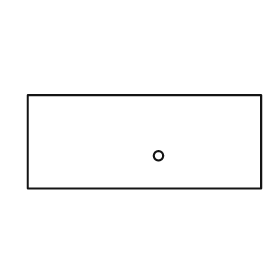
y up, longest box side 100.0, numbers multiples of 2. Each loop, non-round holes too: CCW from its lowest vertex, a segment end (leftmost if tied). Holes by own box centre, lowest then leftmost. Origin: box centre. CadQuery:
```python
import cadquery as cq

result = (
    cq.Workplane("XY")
    .moveTo(-50.0, -20.0)
    .lineTo(50.0, -20.0)
    .lineTo(50.0, 20.0)
    .lineTo(-50.0, 20.0)
    .close()
    .moveTo(6.0, -6.0)
    .circle(2.0)
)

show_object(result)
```